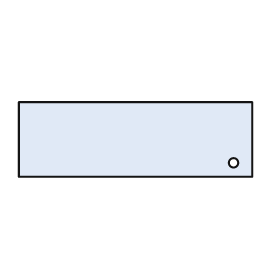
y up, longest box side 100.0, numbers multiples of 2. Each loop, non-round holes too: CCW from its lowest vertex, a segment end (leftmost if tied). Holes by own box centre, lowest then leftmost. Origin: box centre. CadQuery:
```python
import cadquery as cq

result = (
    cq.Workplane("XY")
    .moveTo(-50.0, -16.0)
    .lineTo(50.0, -16.0)
    .lineTo(50.0, 16.0)
    .lineTo(-50.0, 16.0)
    .close()
    .moveTo(42.0, -10.0)
    .circle(2.0)
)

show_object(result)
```